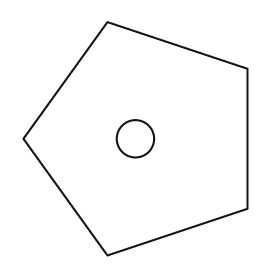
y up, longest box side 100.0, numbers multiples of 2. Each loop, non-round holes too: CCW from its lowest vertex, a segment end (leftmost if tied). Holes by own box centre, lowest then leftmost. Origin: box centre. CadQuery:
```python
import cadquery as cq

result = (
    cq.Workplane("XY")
    .moveTo(-12.0, -50.0)
    .lineTo(48.0, -30.0)
    .lineTo(48.0, 30.0)
    .lineTo(-12.0, 50.0)
    .lineTo(-48.0, 0.0)
    .close()
    .moveTo(0.0, 0.0)
    .circle(8.0)
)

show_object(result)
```